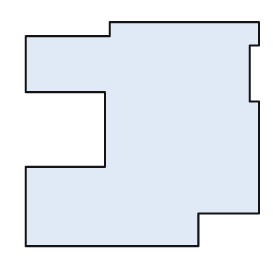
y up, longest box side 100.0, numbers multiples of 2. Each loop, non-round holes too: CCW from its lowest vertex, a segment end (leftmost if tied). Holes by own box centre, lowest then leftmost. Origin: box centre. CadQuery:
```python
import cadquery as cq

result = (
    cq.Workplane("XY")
    .moveTo(-50.0, -48.0)
    .lineTo(24.0, -48.0)
    .lineTo(24.0, -34.0)
    .lineTo(50.0, -34.0)
    .lineTo(50.0, 14.0)
    .lineTo(46.0, 14.0)
    .lineTo(46.0, 38.0)
    .lineTo(50.0, 38.0)
    .lineTo(50.0, 48.0)
    .lineTo(-14.0, 48.0)
    .lineTo(-14.0, 42.0)
    .lineTo(-50.0, 42.0)
    .lineTo(-50.0, 18.0)
    .lineTo(-16.0, 18.0)
    .lineTo(-16.0, -14.0)
    .lineTo(-50.0, -14.0)
    .close()
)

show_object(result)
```